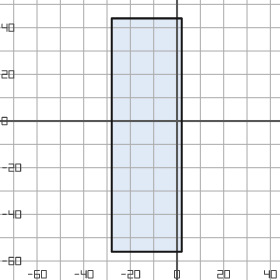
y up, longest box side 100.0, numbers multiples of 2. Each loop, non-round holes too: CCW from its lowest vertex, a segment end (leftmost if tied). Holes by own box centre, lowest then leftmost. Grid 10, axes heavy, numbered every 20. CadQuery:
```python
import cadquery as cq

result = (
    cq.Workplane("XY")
    .moveTo(-28.0, -56.0)
    .lineTo(2.0, -56.0)
    .lineTo(2.0, 44.0)
    .lineTo(-28.0, 44.0)
    .close()
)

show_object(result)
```